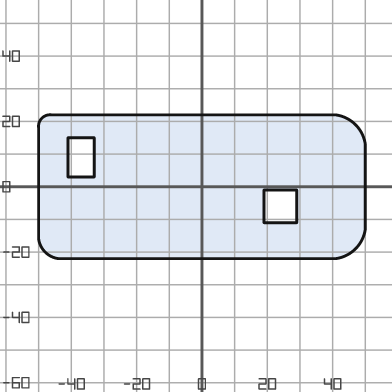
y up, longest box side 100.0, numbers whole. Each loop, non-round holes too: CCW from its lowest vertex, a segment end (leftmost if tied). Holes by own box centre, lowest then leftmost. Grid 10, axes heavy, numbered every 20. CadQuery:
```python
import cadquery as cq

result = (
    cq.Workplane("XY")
    .moveTo(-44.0, -22.0)
    .lineTo(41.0, -22.0)
    .threePointArc((47.0, -19.0), (50.0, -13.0))
    .lineTo(50.0, 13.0)
    .threePointArc((47.0, 19.0), (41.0, 22.0))
    .lineTo(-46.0, 22.0)
    .threePointArc((-49.0, 21.0), (-50.0, 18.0))
    .lineTo(-50.0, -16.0)
    .threePointArc((-48.0, -20.0), (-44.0, -22.0))
    .close()
    .moveTo(19.0, -11.0)
    .lineTo(29.0, -11.0)
    .lineTo(29.0, -1.0)
    .lineTo(19.0, -1.0)
    .close()
    .moveTo(-41.0, 3.0)
    .lineTo(-33.0, 3.0)
    .lineTo(-33.0, 15.0)
    .lineTo(-41.0, 15.0)
    .close()
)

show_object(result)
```